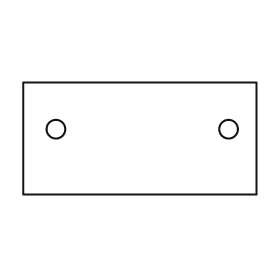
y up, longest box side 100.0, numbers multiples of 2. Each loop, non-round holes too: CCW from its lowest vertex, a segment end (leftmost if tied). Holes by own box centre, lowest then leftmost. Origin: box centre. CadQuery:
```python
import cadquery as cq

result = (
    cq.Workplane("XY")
    .moveTo(-50.0, -24.0)
    .lineTo(50.0, -24.0)
    .lineTo(50.0, 24.0)
    .lineTo(-50.0, 24.0)
    .close()
    .moveTo(-36.0, 4.0)
    .circle(4.0)
    .moveTo(38.0, 4.0)
    .circle(4.0)
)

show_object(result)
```